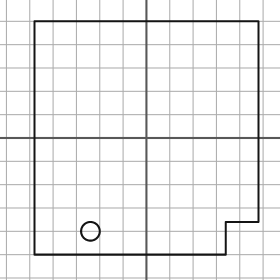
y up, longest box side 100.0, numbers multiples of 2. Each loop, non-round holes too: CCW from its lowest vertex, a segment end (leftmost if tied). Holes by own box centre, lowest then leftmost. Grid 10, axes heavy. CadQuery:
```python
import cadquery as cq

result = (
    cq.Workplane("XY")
    .moveTo(-48.0, -50.0)
    .lineTo(34.0, -50.0)
    .lineTo(34.0, -36.0)
    .lineTo(48.0, -36.0)
    .lineTo(48.0, 50.0)
    .lineTo(-48.0, 50.0)
    .close()
    .moveTo(-24.0, -40.0)
    .circle(4.0)
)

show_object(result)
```